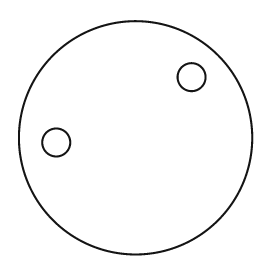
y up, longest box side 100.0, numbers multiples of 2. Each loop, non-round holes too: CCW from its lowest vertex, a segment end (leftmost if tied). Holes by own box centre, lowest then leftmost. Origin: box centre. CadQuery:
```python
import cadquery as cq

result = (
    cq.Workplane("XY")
    .moveTo(0.0, 0.0)
    .circle(50.0)
    .moveTo(-34.0, -2.0)
    .circle(6.0)
    .moveTo(24.0, 26.0)
    .circle(6.0)
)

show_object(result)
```